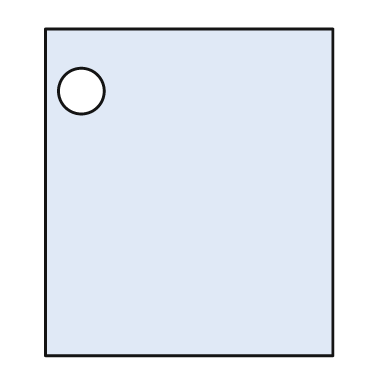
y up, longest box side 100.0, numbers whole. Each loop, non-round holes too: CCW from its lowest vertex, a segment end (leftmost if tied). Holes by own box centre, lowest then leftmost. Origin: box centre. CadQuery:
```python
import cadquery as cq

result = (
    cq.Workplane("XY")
    .moveTo(-44.0, -50.0)
    .lineTo(44.0, -50.0)
    .lineTo(44.0, 50.0)
    .lineTo(-44.0, 50.0)
    .close()
    .moveTo(-33.0, 31.0)
    .circle(7.0)
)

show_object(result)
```